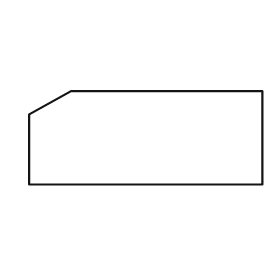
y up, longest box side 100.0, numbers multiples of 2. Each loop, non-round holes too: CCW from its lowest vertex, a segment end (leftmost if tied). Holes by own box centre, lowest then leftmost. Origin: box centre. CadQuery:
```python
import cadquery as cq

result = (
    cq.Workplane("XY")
    .moveTo(-50.0, -20.0)
    .lineTo(50.0, -20.0)
    .lineTo(50.0, 20.0)
    .lineTo(-32.0, 20.0)
    .lineTo(-50.0, 10.0)
    .close()
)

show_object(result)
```